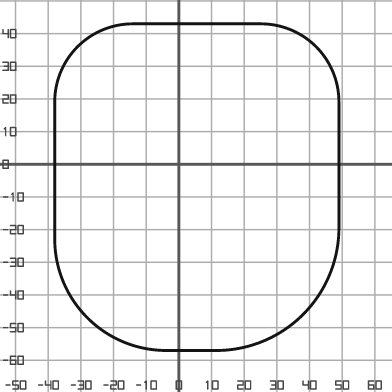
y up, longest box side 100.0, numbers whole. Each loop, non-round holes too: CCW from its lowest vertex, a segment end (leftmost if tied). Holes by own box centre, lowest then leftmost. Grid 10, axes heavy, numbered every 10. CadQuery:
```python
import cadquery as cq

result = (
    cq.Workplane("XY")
    .moveTo(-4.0, -57.0)
    .lineTo(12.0, -57.0)
    .threePointArc((38.0, -46.0), (49.0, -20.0))
    .lineTo(49.0, 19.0)
    .threePointArc((42.0, 36.0), (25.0, 43.0))
    .lineTo(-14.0, 43.0)
    .threePointArc((-31.0, 36.0), (-38.0, 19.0))
    .lineTo(-38.0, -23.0)
    .threePointArc((-28.0, -47.0), (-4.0, -57.0))
    .close()
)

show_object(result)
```